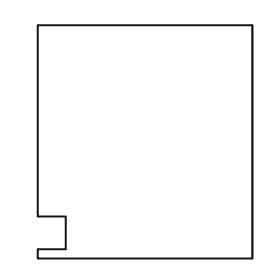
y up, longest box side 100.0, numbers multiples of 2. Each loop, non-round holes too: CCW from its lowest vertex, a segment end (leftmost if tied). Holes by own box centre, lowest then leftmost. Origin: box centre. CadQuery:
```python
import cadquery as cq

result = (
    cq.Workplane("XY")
    .moveTo(-46.0, -50.0)
    .lineTo(46.0, -50.0)
    .lineTo(46.0, 50.0)
    .lineTo(-46.0, 50.0)
    .lineTo(-46.0, -32.0)
    .lineTo(-34.0, -32.0)
    .lineTo(-34.0, -46.0)
    .lineTo(-46.0, -46.0)
    .close()
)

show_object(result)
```